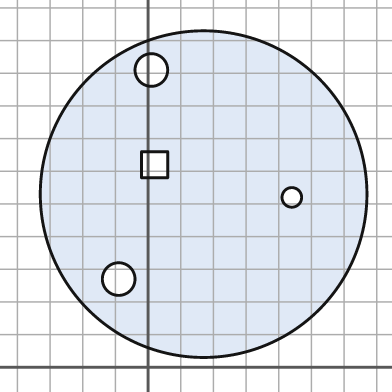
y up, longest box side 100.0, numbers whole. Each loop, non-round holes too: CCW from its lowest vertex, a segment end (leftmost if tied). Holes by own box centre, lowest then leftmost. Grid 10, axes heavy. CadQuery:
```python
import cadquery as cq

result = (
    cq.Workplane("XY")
    .moveTo(17.0, 53.0)
    .circle(50.0)
    .moveTo(-9.0, 27.0)
    .circle(5.0)
    .moveTo(44.0, 52.0)
    .circle(3.0)
    .moveTo(-2.0, 58.0)
    .lineTo(6.0, 58.0)
    .lineTo(6.0, 66.0)
    .lineTo(-2.0, 66.0)
    .close()
    .moveTo(1.0, 91.0)
    .circle(5.0)
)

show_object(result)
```